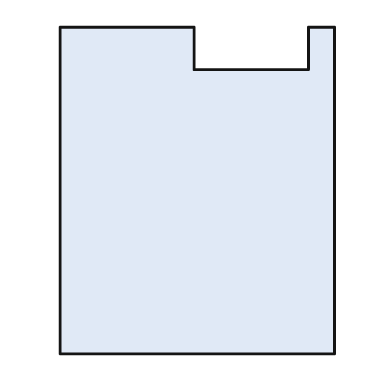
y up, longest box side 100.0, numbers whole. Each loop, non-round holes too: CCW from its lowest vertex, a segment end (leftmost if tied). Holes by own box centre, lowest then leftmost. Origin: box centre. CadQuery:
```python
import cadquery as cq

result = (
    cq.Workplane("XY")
    .moveTo(-42.0, -50.0)
    .lineTo(42.0, -50.0)
    .lineTo(42.0, 50.0)
    .lineTo(34.0, 50.0)
    .lineTo(34.0, 37.0)
    .lineTo(-1.0, 37.0)
    .lineTo(-1.0, 50.0)
    .lineTo(-42.0, 50.0)
    .close()
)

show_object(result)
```